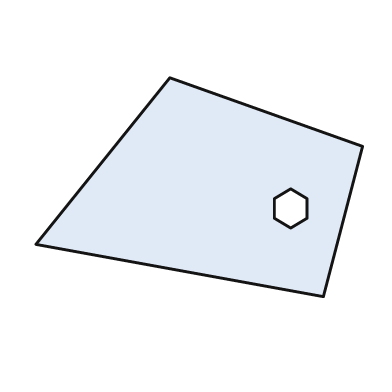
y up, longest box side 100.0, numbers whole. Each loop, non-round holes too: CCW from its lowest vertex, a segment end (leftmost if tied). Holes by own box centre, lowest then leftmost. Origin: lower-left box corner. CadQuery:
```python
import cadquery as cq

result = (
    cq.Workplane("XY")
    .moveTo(88.0, 0.0)
    .lineTo(100.0, 46.0)
    .lineTo(41.0, 67.0)
    .lineTo(0.0, 16.0)
    .close()
    .moveTo(78.0, 21.0)
    .lineTo(83.0, 24.0)
    .lineTo(83.0, 30.0)
    .lineTo(78.0, 33.0)
    .lineTo(73.0, 30.0)
    .lineTo(73.0, 24.0)
    .close()
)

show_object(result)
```